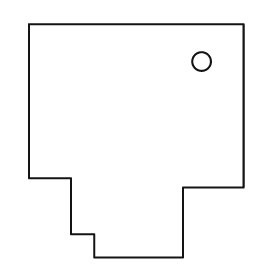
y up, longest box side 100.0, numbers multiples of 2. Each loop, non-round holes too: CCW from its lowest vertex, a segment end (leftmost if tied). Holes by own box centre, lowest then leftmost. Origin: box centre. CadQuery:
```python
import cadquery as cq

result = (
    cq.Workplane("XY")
    .moveTo(-18.0, -50.0)
    .lineTo(20.0, -50.0)
    .lineTo(20.0, -20.0)
    .lineTo(46.0, -20.0)
    .lineTo(46.0, 50.0)
    .lineTo(-46.0, 50.0)
    .lineTo(-46.0, -16.0)
    .lineTo(-28.0, -16.0)
    .lineTo(-28.0, -40.0)
    .lineTo(-18.0, -40.0)
    .close()
    .moveTo(28.0, 34.0)
    .circle(4.0)
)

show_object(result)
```